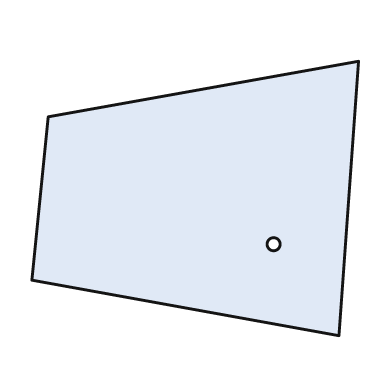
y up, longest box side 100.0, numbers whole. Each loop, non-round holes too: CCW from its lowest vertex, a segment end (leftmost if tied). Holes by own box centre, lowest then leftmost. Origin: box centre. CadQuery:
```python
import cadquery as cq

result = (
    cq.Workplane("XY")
    .moveTo(44.0, -42.0)
    .lineTo(50.0, 42.0)
    .lineTo(-45.0, 25.0)
    .lineTo(-50.0, -25.0)
    .close()
    .moveTo(24.0, -14.0)
    .circle(2.0)
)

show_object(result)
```